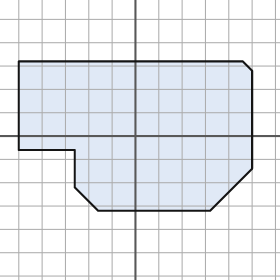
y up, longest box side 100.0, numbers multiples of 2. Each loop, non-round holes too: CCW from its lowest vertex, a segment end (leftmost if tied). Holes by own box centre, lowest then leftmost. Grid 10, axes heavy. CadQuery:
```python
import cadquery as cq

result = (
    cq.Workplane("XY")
    .moveTo(-16.0, -32.0)
    .lineTo(32.0, -32.0)
    .lineTo(50.0, -14.0)
    .lineTo(50.0, 28.0)
    .lineTo(46.0, 32.0)
    .lineTo(-50.0, 32.0)
    .lineTo(-50.0, -6.0)
    .lineTo(-26.0, -6.0)
    .lineTo(-26.0, -22.0)
    .close()
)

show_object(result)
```